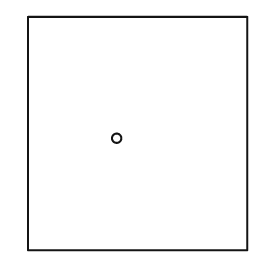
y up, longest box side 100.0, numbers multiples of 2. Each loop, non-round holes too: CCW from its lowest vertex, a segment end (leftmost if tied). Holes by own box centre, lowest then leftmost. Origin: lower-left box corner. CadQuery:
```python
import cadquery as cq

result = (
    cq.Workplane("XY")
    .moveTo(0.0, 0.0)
    .lineTo(94.0, 0.0)
    .lineTo(94.0, 100.0)
    .lineTo(0.0, 100.0)
    .close()
    .moveTo(38.0, 48.0)
    .circle(2.0)
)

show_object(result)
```